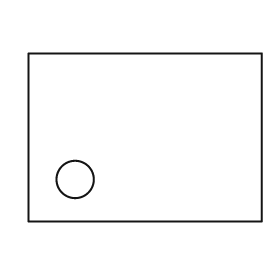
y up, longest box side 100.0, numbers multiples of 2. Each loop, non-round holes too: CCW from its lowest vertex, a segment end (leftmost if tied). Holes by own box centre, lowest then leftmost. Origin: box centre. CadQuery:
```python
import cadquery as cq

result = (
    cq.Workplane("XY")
    .moveTo(-50.0, -36.0)
    .lineTo(50.0, -36.0)
    .lineTo(50.0, 36.0)
    .lineTo(-50.0, 36.0)
    .close()
    .moveTo(-30.0, -18.0)
    .circle(8.0)
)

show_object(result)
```